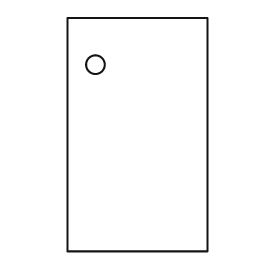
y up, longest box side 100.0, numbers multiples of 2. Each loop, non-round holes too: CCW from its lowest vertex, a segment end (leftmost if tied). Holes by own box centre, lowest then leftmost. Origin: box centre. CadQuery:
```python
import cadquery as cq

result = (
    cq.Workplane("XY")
    .moveTo(-30.0, -50.0)
    .lineTo(30.0, -50.0)
    .lineTo(30.0, 50.0)
    .lineTo(-30.0, 50.0)
    .close()
    .moveTo(-18.0, 30.0)
    .circle(4.0)
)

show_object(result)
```